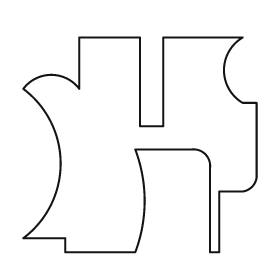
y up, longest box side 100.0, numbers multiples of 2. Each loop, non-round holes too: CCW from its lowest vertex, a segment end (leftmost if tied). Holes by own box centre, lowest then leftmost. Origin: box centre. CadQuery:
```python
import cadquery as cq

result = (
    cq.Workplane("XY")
    .moveTo(-32.0, -46.0)
    .lineTo(-2.0, -46.0)
    .threePointArc((2.0, -24.0), (-2.0, -2.0))
    .lineTo(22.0, -2.0)
    .threePointArc((28.0, -4.0), (30.0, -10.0))
    .lineTo(30.0, -46.0)
    .lineTo(34.0, -46.0)
    .lineTo(34.0, -20.0)
    .lineTo(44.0, -20.0)
    .threePointArc((48.0, -18.0), (50.0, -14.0))
    .lineTo(50.0, 18.0)
    .lineTo(44.0, 18.0)
    .threePointArc((36.0, 32.0), (44.0, 46.0))
    .lineTo(10.0, 46.0)
    .lineTo(10.0, 8.0)
    .lineTo(0.0, 8.0)
    .lineTo(0.0, 46.0)
    .lineTo(-26.0, 46.0)
    .lineTo(-26.0, 24.0)
    .threePointArc((-38.0, 30.0), (-50.0, 24.0))
    .threePointArc((-34.0, -8.0), (-50.0, -40.0))
    .lineTo(-32.0, -40.0)
    .close()
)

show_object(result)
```